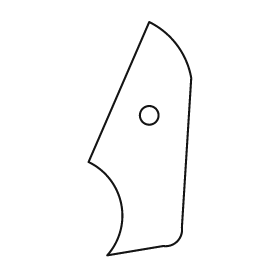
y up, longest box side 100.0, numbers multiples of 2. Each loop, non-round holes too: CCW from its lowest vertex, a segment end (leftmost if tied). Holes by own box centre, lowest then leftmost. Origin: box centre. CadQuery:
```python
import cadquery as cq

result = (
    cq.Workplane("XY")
    .moveTo(-14.0, -50.0)
    .lineTo(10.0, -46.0)
    .threePointArc((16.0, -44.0), (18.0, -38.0))
    .lineTo(22.0, 26.0)
    .threePointArc((16.0, 40.0), (4.0, 50.0))
    .lineTo(-22.0, -10.0)
    .threePointArc((-8.0, -28.0), (-14.0, -50.0))
    .close()
    .moveTo(4.0, 10.0)
    .circle(4.0)
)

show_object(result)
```